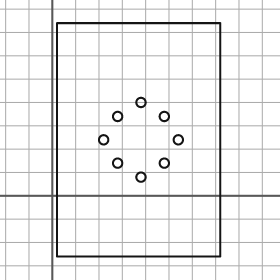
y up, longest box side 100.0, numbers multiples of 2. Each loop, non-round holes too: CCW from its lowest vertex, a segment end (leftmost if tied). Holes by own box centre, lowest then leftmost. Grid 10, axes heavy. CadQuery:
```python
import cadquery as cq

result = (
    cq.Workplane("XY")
    .moveTo(2.0, -26.0)
    .lineTo(72.0, -26.0)
    .lineTo(72.0, 74.0)
    .lineTo(2.0, 74.0)
    .close()
    .moveTo(38.0, 8.0)
    .circle(2.0)
    .moveTo(28.0, 14.0)
    .circle(2.0)
    .moveTo(48.0, 14.0)
    .circle(2.0)
    .moveTo(22.0, 24.0)
    .circle(2.0)
    .moveTo(54.0, 24.0)
    .circle(2.0)
    .moveTo(28.0, 34.0)
    .circle(2.0)
    .moveTo(48.0, 34.0)
    .circle(2.0)
    .moveTo(38.0, 40.0)
    .circle(2.0)
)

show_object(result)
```